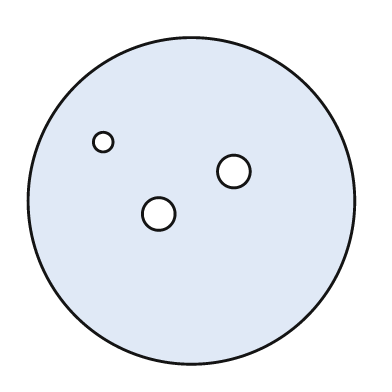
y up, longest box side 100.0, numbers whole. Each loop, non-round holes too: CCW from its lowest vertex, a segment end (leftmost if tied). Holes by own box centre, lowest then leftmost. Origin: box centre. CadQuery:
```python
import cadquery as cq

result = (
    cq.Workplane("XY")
    .moveTo(0.0, 0.0)
    .circle(50.0)
    .moveTo(-10.0, -4.0)
    .circle(5.0)
    .moveTo(13.0, 9.0)
    .circle(5.0)
    .moveTo(-27.0, 18.0)
    .circle(3.0)
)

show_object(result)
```